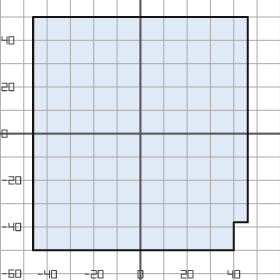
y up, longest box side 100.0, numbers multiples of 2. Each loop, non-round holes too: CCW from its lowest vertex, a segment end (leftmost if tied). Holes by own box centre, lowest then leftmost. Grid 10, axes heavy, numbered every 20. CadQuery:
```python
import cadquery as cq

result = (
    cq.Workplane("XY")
    .moveTo(-46.0, -50.0)
    .lineTo(40.0, -50.0)
    .lineTo(40.0, -38.0)
    .lineTo(46.0, -38.0)
    .lineTo(46.0, 50.0)
    .lineTo(-46.0, 50.0)
    .close()
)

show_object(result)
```